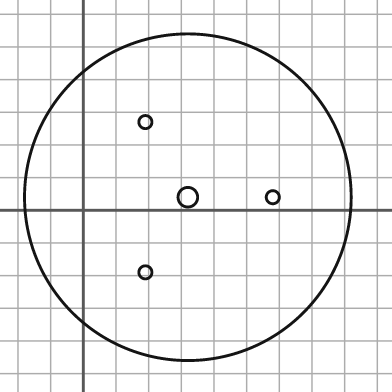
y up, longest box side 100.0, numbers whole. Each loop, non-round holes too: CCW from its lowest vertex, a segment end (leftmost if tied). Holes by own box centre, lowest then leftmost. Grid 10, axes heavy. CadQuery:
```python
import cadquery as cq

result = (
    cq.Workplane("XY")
    .moveTo(32.0, 4.0)
    .circle(50.0)
    .moveTo(19.0, -19.0)
    .circle(2.0)
    .moveTo(32.0, 4.0)
    .circle(3.0)
    .moveTo(58.0, 4.0)
    .circle(2.0)
    .moveTo(19.0, 27.0)
    .circle(2.0)
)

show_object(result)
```